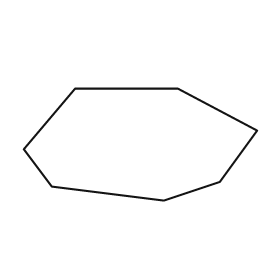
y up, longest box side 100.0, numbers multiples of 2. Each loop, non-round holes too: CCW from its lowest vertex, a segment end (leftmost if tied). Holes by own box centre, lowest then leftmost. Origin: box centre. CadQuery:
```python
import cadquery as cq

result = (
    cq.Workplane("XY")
    .moveTo(10.0, -24.0)
    .lineTo(34.0, -16.0)
    .lineTo(50.0, 6.0)
    .lineTo(16.0, 24.0)
    .lineTo(-28.0, 24.0)
    .lineTo(-50.0, -2.0)
    .lineTo(-38.0, -18.0)
    .close()
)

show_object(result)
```